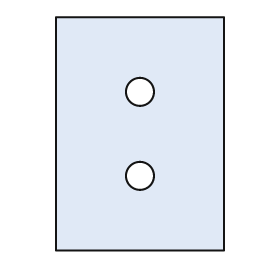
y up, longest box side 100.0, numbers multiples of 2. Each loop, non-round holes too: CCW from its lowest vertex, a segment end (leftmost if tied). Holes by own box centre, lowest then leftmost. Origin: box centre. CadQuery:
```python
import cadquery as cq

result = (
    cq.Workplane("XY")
    .moveTo(-36.0, -50.0)
    .lineTo(36.0, -50.0)
    .lineTo(36.0, 50.0)
    .lineTo(-36.0, 50.0)
    .close()
    .moveTo(0.0, -18.0)
    .circle(6.0)
    .moveTo(0.0, 18.0)
    .circle(6.0)
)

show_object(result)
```